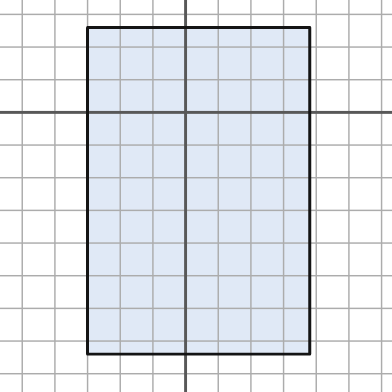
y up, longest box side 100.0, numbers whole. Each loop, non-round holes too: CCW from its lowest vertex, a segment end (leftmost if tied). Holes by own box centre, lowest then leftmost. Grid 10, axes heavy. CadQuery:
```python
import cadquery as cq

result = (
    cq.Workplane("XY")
    .moveTo(-30.0, -74.0)
    .lineTo(38.0, -74.0)
    .lineTo(38.0, 26.0)
    .lineTo(-30.0, 26.0)
    .close()
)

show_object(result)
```